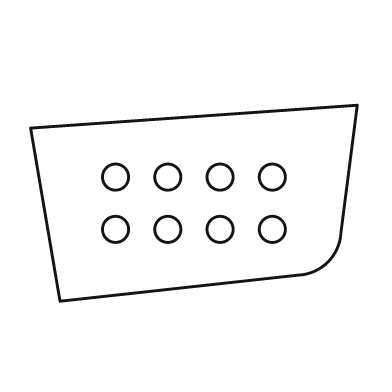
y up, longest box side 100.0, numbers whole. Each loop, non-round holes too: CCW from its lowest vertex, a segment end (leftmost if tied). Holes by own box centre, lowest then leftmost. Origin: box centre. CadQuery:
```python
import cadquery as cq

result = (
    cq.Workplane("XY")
    .moveTo(-41.0, -30.0)
    .lineTo(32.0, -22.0)
    .threePointArc((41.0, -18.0), (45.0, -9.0))
    .lineTo(50.0, 30.0)
    .lineTo(-50.0, 23.0)
    .close()
    .moveTo(-24.0, -8.0)
    .circle(4.0)
    .moveTo(-8.0, -8.0)
    .circle(4.0)
    .moveTo(8.0, -8.0)
    .circle(4.0)
    .moveTo(24.0, -8.0)
    .circle(4.0)
    .moveTo(-24.0, 8.0)
    .circle(4.0)
    .moveTo(-8.0, 8.0)
    .circle(4.0)
    .moveTo(8.0, 8.0)
    .circle(4.0)
    .moveTo(24.0, 8.0)
    .circle(4.0)
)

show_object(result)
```